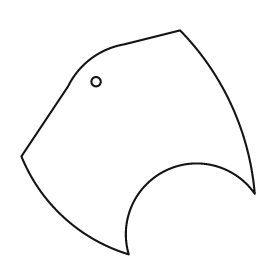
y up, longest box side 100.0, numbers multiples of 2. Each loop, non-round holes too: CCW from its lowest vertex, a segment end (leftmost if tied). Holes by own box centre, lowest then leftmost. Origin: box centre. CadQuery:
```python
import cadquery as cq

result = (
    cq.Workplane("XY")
    .moveTo(-4.0, -48.0)
    .threePointArc((12.0, -12.0), (50.0, -22.0))
    .threePointArc((40.0, 16.0), (18.0, 48.0))
    .lineTo(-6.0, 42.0)
    .threePointArc((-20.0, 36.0), (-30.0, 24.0))
    .lineTo(-50.0, -6.0)
    .threePointArc((-32.0, -32.0), (-4.0, -48.0))
    .close()
    .moveTo(-18.0, 26.0)
    .circle(2.0)
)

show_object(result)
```